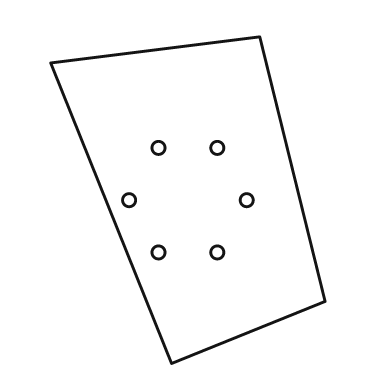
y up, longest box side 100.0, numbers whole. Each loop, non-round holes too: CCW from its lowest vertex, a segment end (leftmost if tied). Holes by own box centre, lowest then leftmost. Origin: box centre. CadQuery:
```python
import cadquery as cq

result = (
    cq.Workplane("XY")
    .moveTo(-5.0, -50.0)
    .lineTo(42.0, -31.0)
    .lineTo(22.0, 50.0)
    .lineTo(-42.0, 42.0)
    .close()
    .moveTo(-9.0, -16.0)
    .circle(2.0)
    .moveTo(9.0, -16.0)
    .circle(2.0)
    .moveTo(-18.0, 0.0)
    .circle(2.0)
    .moveTo(18.0, 0.0)
    .circle(2.0)
    .moveTo(-9.0, 16.0)
    .circle(2.0)
    .moveTo(9.0, 16.0)
    .circle(2.0)
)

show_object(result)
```